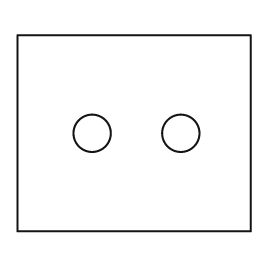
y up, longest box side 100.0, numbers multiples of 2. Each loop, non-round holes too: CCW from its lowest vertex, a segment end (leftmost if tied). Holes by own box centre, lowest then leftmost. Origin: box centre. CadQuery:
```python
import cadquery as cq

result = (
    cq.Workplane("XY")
    .moveTo(-50.0, -42.0)
    .lineTo(50.0, -42.0)
    .lineTo(50.0, 42.0)
    .lineTo(-50.0, 42.0)
    .close()
    .moveTo(-18.0, 0.0)
    .circle(8.0)
    .moveTo(20.0, 0.0)
    .circle(8.0)
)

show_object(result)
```